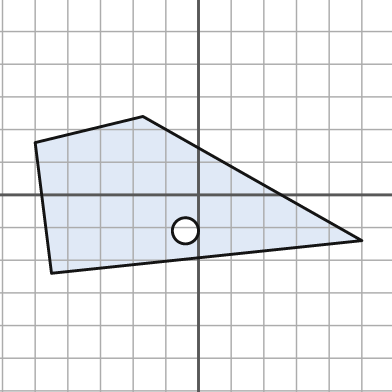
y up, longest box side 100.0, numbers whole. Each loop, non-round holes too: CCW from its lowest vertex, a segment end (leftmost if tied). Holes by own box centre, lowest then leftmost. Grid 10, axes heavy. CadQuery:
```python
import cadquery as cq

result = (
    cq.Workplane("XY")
    .moveTo(-45.0, -24.0)
    .lineTo(50.0, -14.0)
    .lineTo(-17.0, 24.0)
    .lineTo(-50.0, 16.0)
    .close()
    .moveTo(-4.0, -11.0)
    .circle(4.0)
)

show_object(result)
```